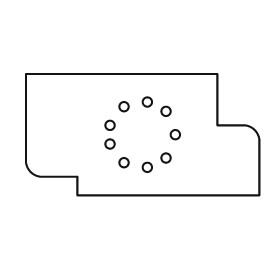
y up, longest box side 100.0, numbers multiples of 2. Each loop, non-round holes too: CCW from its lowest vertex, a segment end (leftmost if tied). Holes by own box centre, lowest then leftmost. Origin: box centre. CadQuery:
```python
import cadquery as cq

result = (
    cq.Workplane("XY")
    .moveTo(-28.0, -26.0)
    .lineTo(50.0, -26.0)
    .lineTo(50.0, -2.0)
    .threePointArc((48.0, 2.0), (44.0, 4.0))
    .lineTo(32.0, 4.0)
    .lineTo(32.0, 26.0)
    .lineTo(-50.0, 26.0)
    .lineTo(-50.0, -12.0)
    .threePointArc((-48.0, -16.0), (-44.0, -18.0))
    .lineTo(-28.0, -18.0)
    .close()
    .moveTo(2.0, -14.0)
    .circle(2.0)
    .moveTo(-8.0, -12.0)
    .circle(2.0)
    .moveTo(10.0, -10.0)
    .circle(2.0)
    .moveTo(-14.0, -4.0)
    .circle(2.0)
    .moveTo(14.0, 0.0)
    .circle(2.0)
    .moveTo(-14.0, 4.0)
    .circle(2.0)
    .moveTo(10.0, 10.0)
    .circle(2.0)
    .moveTo(-8.0, 12.0)
    .circle(2.0)
    .moveTo(2.0, 14.0)
    .circle(2.0)
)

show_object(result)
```